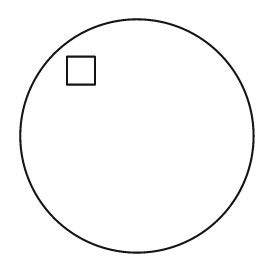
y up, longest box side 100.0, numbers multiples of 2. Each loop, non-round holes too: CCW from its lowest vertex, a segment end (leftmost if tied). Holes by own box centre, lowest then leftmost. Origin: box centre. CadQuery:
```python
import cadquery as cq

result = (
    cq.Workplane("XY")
    .moveTo(0.0, 0.0)
    .circle(50.0)
    .moveTo(-30.0, 22.0)
    .lineTo(-18.0, 22.0)
    .lineTo(-18.0, 34.0)
    .lineTo(-30.0, 34.0)
    .close()
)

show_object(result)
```